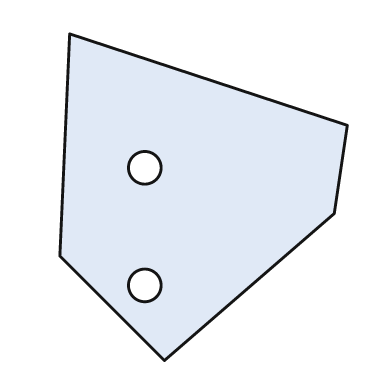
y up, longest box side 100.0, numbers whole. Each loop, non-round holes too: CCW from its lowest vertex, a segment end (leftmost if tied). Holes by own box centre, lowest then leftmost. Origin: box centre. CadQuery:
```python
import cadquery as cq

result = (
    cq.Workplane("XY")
    .moveTo(-12.0, -50.0)
    .lineTo(40.0, -5.0)
    .lineTo(44.0, 22.0)
    .lineTo(-41.0, 50.0)
    .lineTo(-44.0, -18.0)
    .close()
    .moveTo(-18.0, -27.0)
    .circle(5.0)
    .moveTo(-18.0, 9.0)
    .circle(5.0)
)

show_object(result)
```